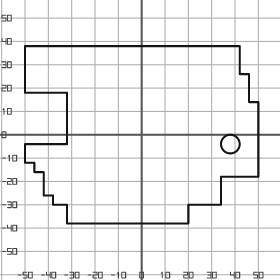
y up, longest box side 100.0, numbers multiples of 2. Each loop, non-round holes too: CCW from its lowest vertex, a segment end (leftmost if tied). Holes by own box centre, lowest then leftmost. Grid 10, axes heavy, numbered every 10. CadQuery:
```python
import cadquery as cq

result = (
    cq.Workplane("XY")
    .moveTo(-32.0, -38.0)
    .lineTo(20.0, -38.0)
    .lineTo(20.0, -30.0)
    .lineTo(34.0, -30.0)
    .lineTo(34.0, -18.0)
    .lineTo(50.0, -18.0)
    .lineTo(50.0, 14.0)
    .lineTo(46.0, 14.0)
    .lineTo(46.0, 26.0)
    .lineTo(42.0, 26.0)
    .lineTo(42.0, 38.0)
    .lineTo(-50.0, 38.0)
    .lineTo(-50.0, 18.0)
    .lineTo(-32.0, 18.0)
    .lineTo(-32.0, -4.0)
    .lineTo(-50.0, -4.0)
    .lineTo(-50.0, -12.0)
    .lineTo(-46.0, -12.0)
    .lineTo(-46.0, -16.0)
    .lineTo(-42.0, -16.0)
    .lineTo(-42.0, -26.0)
    .lineTo(-38.0, -26.0)
    .lineTo(-38.0, -30.0)
    .lineTo(-32.0, -30.0)
    .close()
    .moveTo(38.0, -4.0)
    .circle(4.0)
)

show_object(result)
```